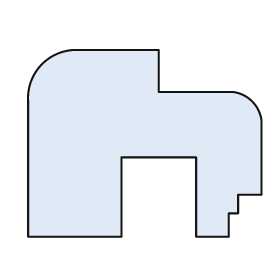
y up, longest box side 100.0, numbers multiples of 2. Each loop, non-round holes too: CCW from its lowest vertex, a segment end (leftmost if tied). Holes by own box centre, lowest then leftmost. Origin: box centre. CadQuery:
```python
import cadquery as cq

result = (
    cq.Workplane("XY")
    .moveTo(-50.0, -40.0)
    .lineTo(-10.0, -40.0)
    .lineTo(-10.0, -6.0)
    .lineTo(22.0, -6.0)
    .lineTo(22.0, -40.0)
    .lineTo(36.0, -40.0)
    .lineTo(36.0, -30.0)
    .lineTo(40.0, -30.0)
    .lineTo(40.0, -22.0)
    .lineTo(50.0, -22.0)
    .lineTo(50.0, 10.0)
    .threePointArc((46.0, 18.0), (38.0, 22.0))
    .lineTo(6.0, 22.0)
    .lineTo(6.0, 40.0)
    .lineTo(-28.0, 40.0)
    .threePointArc((-44.0, 34.0), (-50.0, 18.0))
    .close()
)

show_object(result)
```